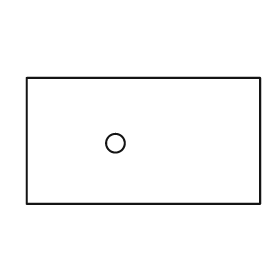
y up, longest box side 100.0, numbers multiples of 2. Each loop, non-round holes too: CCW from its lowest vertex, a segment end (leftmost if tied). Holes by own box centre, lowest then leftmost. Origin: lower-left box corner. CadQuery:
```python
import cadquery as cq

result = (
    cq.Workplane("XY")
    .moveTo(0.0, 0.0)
    .lineTo(100.0, 0.0)
    .lineTo(100.0, 54.0)
    .lineTo(0.0, 54.0)
    .close()
    .moveTo(38.0, 26.0)
    .circle(4.0)
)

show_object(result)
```